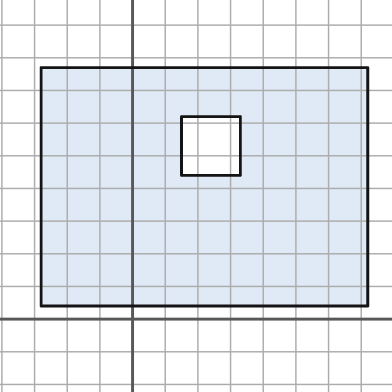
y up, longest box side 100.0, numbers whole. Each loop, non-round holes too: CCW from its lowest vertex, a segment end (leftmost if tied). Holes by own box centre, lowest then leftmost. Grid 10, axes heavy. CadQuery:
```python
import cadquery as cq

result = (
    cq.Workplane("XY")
    .moveTo(-28.0, 4.0)
    .lineTo(72.0, 4.0)
    .lineTo(72.0, 77.0)
    .lineTo(-28.0, 77.0)
    .close()
    .moveTo(15.0, 44.0)
    .lineTo(33.0, 44.0)
    .lineTo(33.0, 62.0)
    .lineTo(15.0, 62.0)
    .close()
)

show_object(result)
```